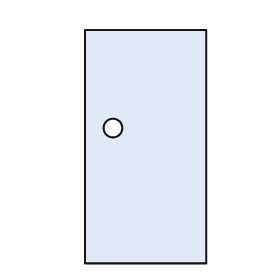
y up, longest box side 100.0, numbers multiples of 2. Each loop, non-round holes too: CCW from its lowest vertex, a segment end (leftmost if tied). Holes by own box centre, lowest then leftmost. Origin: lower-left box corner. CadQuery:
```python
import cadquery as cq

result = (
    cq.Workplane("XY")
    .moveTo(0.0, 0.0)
    .lineTo(52.0, 0.0)
    .lineTo(52.0, 100.0)
    .lineTo(0.0, 100.0)
    .close()
    .moveTo(12.0, 58.0)
    .circle(4.0)
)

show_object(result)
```